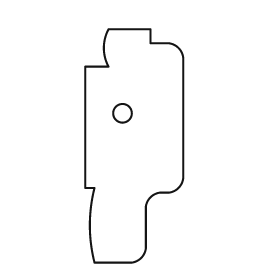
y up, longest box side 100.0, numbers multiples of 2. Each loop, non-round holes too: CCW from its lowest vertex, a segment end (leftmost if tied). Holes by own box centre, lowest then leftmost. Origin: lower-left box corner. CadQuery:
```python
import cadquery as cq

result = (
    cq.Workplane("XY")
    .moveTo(4.0, 0.0)
    .lineTo(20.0, 0.0)
    .threePointArc((24.0, 2.0), (26.0, 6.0))
    .lineTo(26.0, 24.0)
    .threePointArc((28.0, 28.0), (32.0, 30.0))
    .lineTo(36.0, 30.0)
    .threePointArc((40.0, 32.0), (42.0, 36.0))
    .lineTo(42.0, 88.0)
    .threePointArc((40.0, 92.0), (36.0, 94.0))
    .lineTo(28.0, 94.0)
    .lineTo(28.0, 100.0)
    .lineTo(10.0, 100.0)
    .threePointArc((8.0, 92.0), (10.0, 84.0))
    .lineTo(0.0, 84.0)
    .lineTo(0.0, 32.0)
    .lineTo(4.0, 32.0)
    .threePointArc((2.0, 16.0), (4.0, 0.0))
    .close()
    .moveTo(16.0, 64.0)
    .circle(4.0)
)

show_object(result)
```